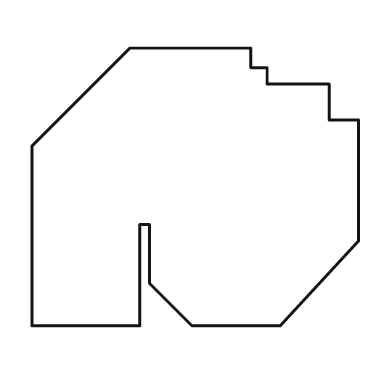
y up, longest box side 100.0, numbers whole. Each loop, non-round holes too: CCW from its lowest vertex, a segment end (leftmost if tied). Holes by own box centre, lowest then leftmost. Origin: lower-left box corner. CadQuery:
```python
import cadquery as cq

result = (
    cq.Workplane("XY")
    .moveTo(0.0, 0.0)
    .lineTo(33.0, 0.0)
    .lineTo(33.0, 31.0)
    .lineTo(36.0, 31.0)
    .lineTo(36.0, 13.0)
    .lineTo(49.0, 0.0)
    .lineTo(76.0, 0.0)
    .lineTo(100.0, 26.0)
    .lineTo(100.0, 63.0)
    .lineTo(91.0, 63.0)
    .lineTo(91.0, 74.0)
    .lineTo(72.0, 74.0)
    .lineTo(72.0, 79.0)
    .lineTo(67.0, 79.0)
    .lineTo(67.0, 85.0)
    .lineTo(30.0, 85.0)
    .lineTo(0.0, 55.0)
    .close()
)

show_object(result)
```